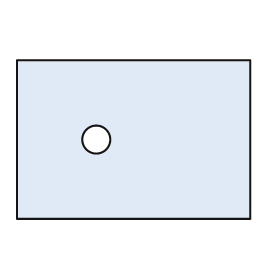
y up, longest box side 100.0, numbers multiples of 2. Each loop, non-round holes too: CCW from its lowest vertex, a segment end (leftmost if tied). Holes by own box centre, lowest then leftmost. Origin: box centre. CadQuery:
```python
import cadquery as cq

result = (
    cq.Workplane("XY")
    .moveTo(-50.0, -34.0)
    .lineTo(50.0, -34.0)
    .lineTo(50.0, 34.0)
    .lineTo(-50.0, 34.0)
    .close()
    .moveTo(-16.0, 0.0)
    .circle(6.0)
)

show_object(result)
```